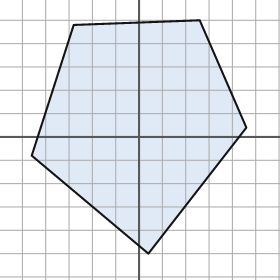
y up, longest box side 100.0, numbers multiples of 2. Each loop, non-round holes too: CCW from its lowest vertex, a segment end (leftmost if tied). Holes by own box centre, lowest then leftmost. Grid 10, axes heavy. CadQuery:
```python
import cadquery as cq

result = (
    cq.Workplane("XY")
    .moveTo(4.0, -50.0)
    .lineTo(46.0, 4.0)
    .lineTo(26.0, 50.0)
    .lineTo(-28.0, 48.0)
    .lineTo(-46.0, -8.0)
    .close()
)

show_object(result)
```